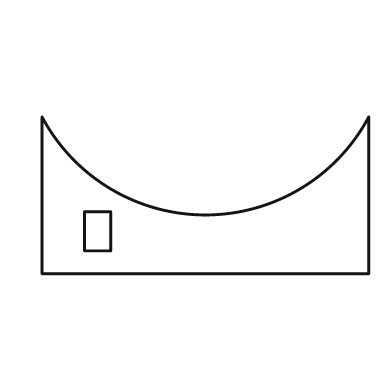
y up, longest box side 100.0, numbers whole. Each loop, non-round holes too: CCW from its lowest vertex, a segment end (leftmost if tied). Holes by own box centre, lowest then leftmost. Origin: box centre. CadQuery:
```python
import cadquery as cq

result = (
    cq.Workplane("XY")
    .moveTo(-50.0, -24.0)
    .lineTo(50.0, -24.0)
    .lineTo(50.0, 24.0)
    .threePointArc((0.0, -6.0), (-50.0, 24.0))
    .close()
    .moveTo(-37.0, -17.0)
    .lineTo(-29.0, -17.0)
    .lineTo(-29.0, -5.0)
    .lineTo(-37.0, -5.0)
    .close()
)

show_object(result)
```